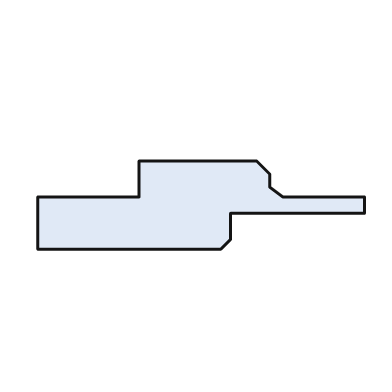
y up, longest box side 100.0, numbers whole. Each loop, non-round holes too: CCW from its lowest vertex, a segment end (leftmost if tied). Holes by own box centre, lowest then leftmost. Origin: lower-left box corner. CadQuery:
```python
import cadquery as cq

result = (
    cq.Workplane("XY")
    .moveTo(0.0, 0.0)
    .lineTo(56.0, 0.0)
    .lineTo(59.0, 3.0)
    .lineTo(59.0, 11.0)
    .lineTo(100.0, 11.0)
    .lineTo(100.0, 16.0)
    .lineTo(75.0, 16.0)
    .lineTo(71.0, 19.0)
    .lineTo(71.0, 23.0)
    .lineTo(67.0, 27.0)
    .lineTo(31.0, 27.0)
    .lineTo(31.0, 16.0)
    .lineTo(0.0, 16.0)
    .close()
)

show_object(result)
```